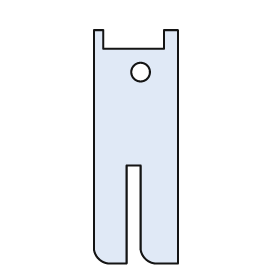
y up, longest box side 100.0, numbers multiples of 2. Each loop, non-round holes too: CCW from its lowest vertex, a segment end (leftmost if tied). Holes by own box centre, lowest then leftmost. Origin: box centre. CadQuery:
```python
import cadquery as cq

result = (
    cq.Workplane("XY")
    .moveTo(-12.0, -50.0)
    .lineTo(-4.0, -50.0)
    .lineTo(-4.0, -8.0)
    .lineTo(2.0, -8.0)
    .lineTo(2.0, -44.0)
    .threePointArc((4.0, -48.0), (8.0, -50.0))
    .lineTo(18.0, -50.0)
    .lineTo(18.0, 50.0)
    .lineTo(12.0, 50.0)
    .lineTo(12.0, 42.0)
    .lineTo(-14.0, 42.0)
    .lineTo(-14.0, 50.0)
    .lineTo(-18.0, 50.0)
    .lineTo(-18.0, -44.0)
    .threePointArc((-16.0, -48.0), (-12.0, -50.0))
    .close()
    .moveTo(2.0, 32.0)
    .circle(4.0)
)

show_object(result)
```